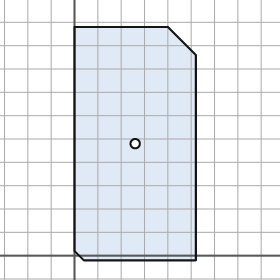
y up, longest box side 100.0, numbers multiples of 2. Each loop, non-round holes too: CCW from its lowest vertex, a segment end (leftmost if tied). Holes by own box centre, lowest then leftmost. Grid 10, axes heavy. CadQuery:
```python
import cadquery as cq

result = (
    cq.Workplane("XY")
    .moveTo(4.0, -2.0)
    .lineTo(52.0, -2.0)
    .lineTo(52.0, 86.0)
    .lineTo(40.0, 98.0)
    .lineTo(0.0, 98.0)
    .lineTo(0.0, 2.0)
    .close()
    .moveTo(26.0, 48.0)
    .circle(2.0)
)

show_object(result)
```